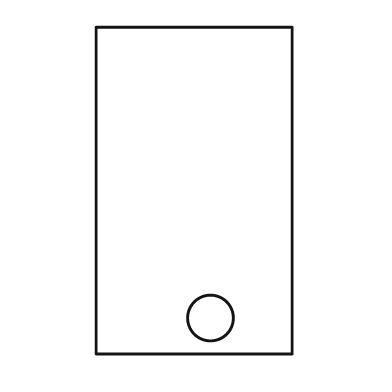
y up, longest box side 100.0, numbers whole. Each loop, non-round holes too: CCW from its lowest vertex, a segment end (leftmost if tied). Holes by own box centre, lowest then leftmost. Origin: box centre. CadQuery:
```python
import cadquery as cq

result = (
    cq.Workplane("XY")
    .moveTo(-30.0, -50.0)
    .lineTo(30.0, -50.0)
    .lineTo(30.0, 50.0)
    .lineTo(-30.0, 50.0)
    .close()
    .moveTo(5.0, -39.0)
    .circle(7.0)
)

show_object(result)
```